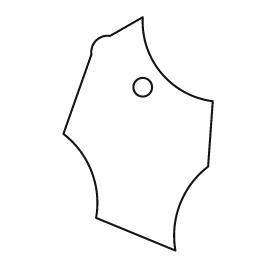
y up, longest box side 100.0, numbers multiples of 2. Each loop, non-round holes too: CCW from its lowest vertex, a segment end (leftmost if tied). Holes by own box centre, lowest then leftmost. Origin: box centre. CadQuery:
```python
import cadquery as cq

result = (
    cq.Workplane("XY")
    .moveTo(16.0, -50.0)
    .threePointArc((18.0, -30.0), (30.0, -14.0))
    .lineTo(32.0, 14.0)
    .threePointArc((10.0, 26.0), (2.0, 50.0))
    .lineTo(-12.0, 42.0)
    .threePointArc((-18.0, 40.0), (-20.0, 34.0))
    .lineTo(-32.0, 0.0)
    .threePointArc((-20.0, -16.0), (-18.0, -36.0))
    .close()
    .moveTo(2.0, 20.0)
    .circle(4.0)
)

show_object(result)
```